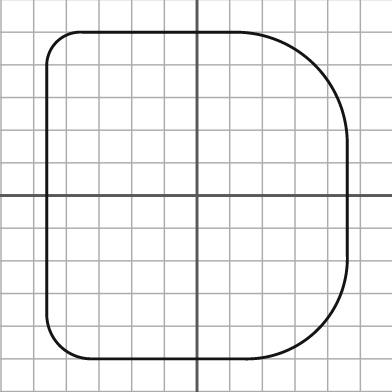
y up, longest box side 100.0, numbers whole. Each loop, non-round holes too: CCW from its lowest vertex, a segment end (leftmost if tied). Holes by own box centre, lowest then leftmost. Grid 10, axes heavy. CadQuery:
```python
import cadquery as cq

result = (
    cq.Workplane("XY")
    .moveTo(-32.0, -50.0)
    .lineTo(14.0, -50.0)
    .threePointArc((37.0, -41.0), (46.0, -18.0))
    .lineTo(46.0, 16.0)
    .threePointArc((36.0, 40.0), (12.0, 50.0))
    .lineTo(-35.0, 50.0)
    .threePointArc((-43.0, 47.0), (-46.0, 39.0))
    .lineTo(-46.0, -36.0)
    .threePointArc((-42.0, -46.0), (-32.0, -50.0))
    .close()
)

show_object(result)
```